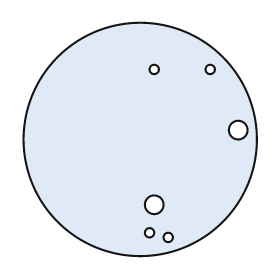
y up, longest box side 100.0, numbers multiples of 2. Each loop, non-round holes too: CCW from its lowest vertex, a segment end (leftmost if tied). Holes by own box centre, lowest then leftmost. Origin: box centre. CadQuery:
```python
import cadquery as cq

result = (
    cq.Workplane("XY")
    .moveTo(0.0, 0.0)
    .circle(50.0)
    .moveTo(12.0, -42.0)
    .circle(2.0)
    .moveTo(4.0, -40.0)
    .circle(2.0)
    .moveTo(6.0, -28.0)
    .circle(4.0)
    .moveTo(42.0, 4.0)
    .circle(4.0)
    .moveTo(6.0, 30.0)
    .circle(2.0)
    .moveTo(30.0, 30.0)
    .circle(2.0)
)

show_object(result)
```